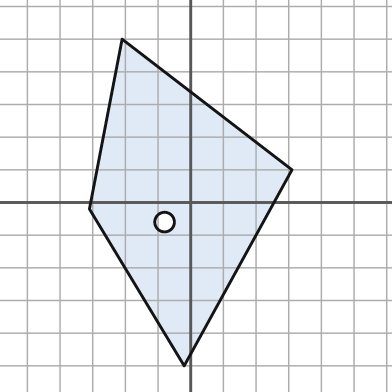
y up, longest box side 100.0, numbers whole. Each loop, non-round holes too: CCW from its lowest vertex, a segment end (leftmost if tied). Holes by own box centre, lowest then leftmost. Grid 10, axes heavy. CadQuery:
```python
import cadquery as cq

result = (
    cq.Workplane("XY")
    .moveTo(-2.0, -50.0)
    .lineTo(31.0, 10.0)
    .lineTo(-21.0, 50.0)
    .lineTo(-31.0, -2.0)
    .close()
    .moveTo(-8.0, -6.0)
    .circle(3.0)
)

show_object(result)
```